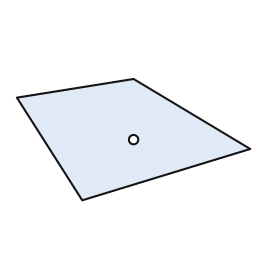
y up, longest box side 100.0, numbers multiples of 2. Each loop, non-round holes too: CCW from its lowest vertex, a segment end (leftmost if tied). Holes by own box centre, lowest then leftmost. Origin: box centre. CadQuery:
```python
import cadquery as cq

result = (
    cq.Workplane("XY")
    .moveTo(-22.0, -26.0)
    .lineTo(50.0, -4.0)
    .lineTo(0.0, 26.0)
    .lineTo(-50.0, 18.0)
    .close()
    .moveTo(0.0, 0.0)
    .circle(2.0)
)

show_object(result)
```